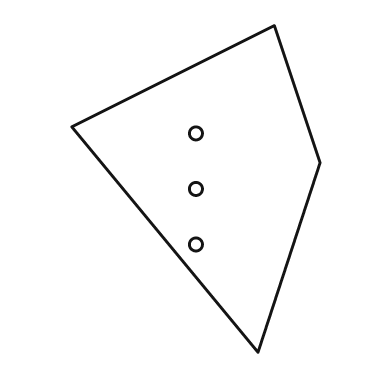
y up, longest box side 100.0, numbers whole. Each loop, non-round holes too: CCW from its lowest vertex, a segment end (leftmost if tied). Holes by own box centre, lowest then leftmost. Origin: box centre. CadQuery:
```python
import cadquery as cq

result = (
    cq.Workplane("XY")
    .moveTo(19.0, -50.0)
    .lineTo(38.0, 8.0)
    .lineTo(24.0, 50.0)
    .lineTo(-38.0, 19.0)
    .close()
    .moveTo(0.0, -17.0)
    .circle(2.0)
    .moveTo(0.0, 0.0)
    .circle(2.0)
    .moveTo(0.0, 17.0)
    .circle(2.0)
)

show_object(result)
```